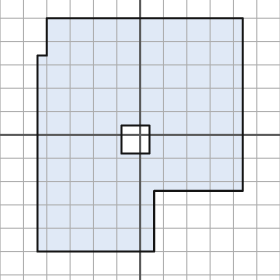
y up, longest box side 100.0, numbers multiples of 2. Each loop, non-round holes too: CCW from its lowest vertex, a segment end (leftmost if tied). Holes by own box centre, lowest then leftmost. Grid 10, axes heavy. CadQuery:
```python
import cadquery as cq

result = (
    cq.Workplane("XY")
    .moveTo(-44.0, -50.0)
    .lineTo(6.0, -50.0)
    .lineTo(6.0, -24.0)
    .lineTo(44.0, -24.0)
    .lineTo(44.0, 50.0)
    .lineTo(-40.0, 50.0)
    .lineTo(-40.0, 34.0)
    .lineTo(-44.0, 34.0)
    .close()
    .moveTo(-8.0, -8.0)
    .lineTo(4.0, -8.0)
    .lineTo(4.0, 4.0)
    .lineTo(-8.0, 4.0)
    .close()
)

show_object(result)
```